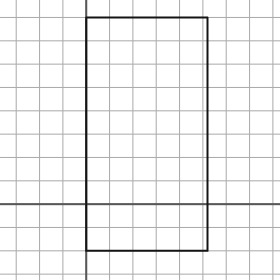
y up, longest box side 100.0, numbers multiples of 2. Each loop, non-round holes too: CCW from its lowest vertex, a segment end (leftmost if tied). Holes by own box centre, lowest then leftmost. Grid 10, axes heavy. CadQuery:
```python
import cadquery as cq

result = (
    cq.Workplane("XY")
    .moveTo(0.0, -20.0)
    .lineTo(52.0, -20.0)
    .lineTo(52.0, 80.0)
    .lineTo(0.0, 80.0)
    .close()
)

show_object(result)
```